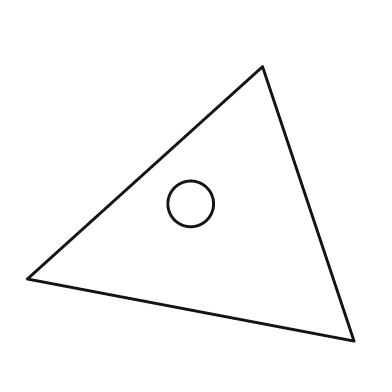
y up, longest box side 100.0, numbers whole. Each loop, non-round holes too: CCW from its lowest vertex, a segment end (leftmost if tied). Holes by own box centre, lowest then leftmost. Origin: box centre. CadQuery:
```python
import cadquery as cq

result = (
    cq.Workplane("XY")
    .moveTo(50.0, -42.0)
    .lineTo(22.0, 42.0)
    .lineTo(-50.0, -23.0)
    .close()
    .moveTo(0.0, 0.0)
    .circle(7.0)
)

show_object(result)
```